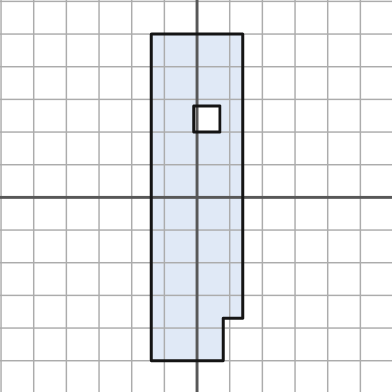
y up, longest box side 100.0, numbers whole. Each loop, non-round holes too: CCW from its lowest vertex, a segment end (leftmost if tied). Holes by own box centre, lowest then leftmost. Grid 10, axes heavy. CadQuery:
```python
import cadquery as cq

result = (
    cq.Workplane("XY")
    .moveTo(-14.0, -50.0)
    .lineTo(8.0, -50.0)
    .lineTo(8.0, -37.0)
    .lineTo(14.0, -37.0)
    .lineTo(14.0, 50.0)
    .lineTo(-14.0, 50.0)
    .close()
    .moveTo(-1.0, 20.0)
    .lineTo(7.0, 20.0)
    .lineTo(7.0, 28.0)
    .lineTo(-1.0, 28.0)
    .close()
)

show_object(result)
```